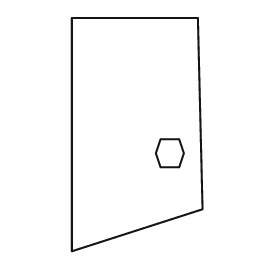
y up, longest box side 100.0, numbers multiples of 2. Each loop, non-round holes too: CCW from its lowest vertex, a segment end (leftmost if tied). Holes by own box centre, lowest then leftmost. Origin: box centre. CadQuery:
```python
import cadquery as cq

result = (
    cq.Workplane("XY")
    .moveTo(-28.0, -50.0)
    .lineTo(28.0, -32.0)
    .lineTo(26.0, 50.0)
    .lineTo(-28.0, 50.0)
    .close()
    .moveTo(10.0, -14.0)
    .lineTo(18.0, -14.0)
    .lineTo(20.0, -8.0)
    .lineTo(18.0, -2.0)
    .lineTo(10.0, -2.0)
    .lineTo(8.0, -8.0)
    .close()
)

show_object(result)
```